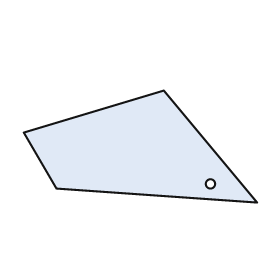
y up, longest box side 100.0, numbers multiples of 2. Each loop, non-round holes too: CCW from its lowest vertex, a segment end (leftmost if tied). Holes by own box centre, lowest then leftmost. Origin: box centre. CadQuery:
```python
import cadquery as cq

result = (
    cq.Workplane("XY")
    .moveTo(50.0, -24.0)
    .lineTo(10.0, 24.0)
    .lineTo(-50.0, 6.0)
    .lineTo(-36.0, -18.0)
    .close()
    .moveTo(30.0, -16.0)
    .circle(2.0)
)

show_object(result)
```